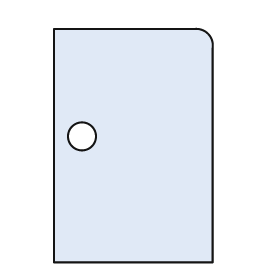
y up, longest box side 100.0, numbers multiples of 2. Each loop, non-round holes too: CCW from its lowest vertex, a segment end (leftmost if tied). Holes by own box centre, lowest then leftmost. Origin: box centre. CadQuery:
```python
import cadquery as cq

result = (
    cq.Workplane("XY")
    .moveTo(-34.0, -50.0)
    .lineTo(34.0, -50.0)
    .lineTo(34.0, 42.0)
    .threePointArc((32.0, 48.0), (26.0, 50.0))
    .lineTo(-34.0, 50.0)
    .close()
    .moveTo(-22.0, 4.0)
    .circle(6.0)
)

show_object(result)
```